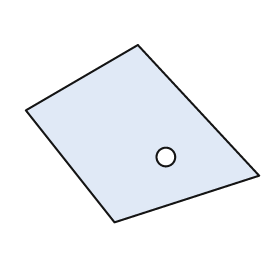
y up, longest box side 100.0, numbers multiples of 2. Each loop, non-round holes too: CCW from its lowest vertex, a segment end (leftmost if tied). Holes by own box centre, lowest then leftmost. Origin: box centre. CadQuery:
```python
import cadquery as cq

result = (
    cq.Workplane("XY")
    .moveTo(-12.0, -38.0)
    .lineTo(50.0, -18.0)
    .lineTo(-2.0, 38.0)
    .lineTo(-50.0, 10.0)
    .close()
    .moveTo(10.0, -10.0)
    .circle(4.0)
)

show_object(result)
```